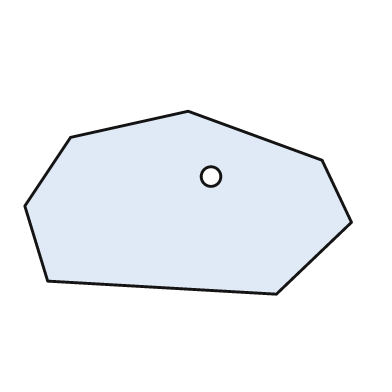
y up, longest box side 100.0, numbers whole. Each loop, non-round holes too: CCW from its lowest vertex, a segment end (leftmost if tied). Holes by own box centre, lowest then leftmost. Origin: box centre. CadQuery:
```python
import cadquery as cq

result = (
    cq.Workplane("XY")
    .moveTo(27.0, -28.0)
    .lineTo(50.0, -6.0)
    .lineTo(41.0, 13.0)
    .lineTo(0.0, 28.0)
    .lineTo(-36.0, 20.0)
    .lineTo(-50.0, -1.0)
    .lineTo(-43.0, -24.0)
    .close()
    .moveTo(7.0, 8.0)
    .circle(3.0)
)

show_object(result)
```